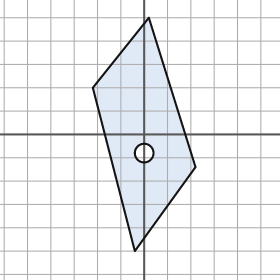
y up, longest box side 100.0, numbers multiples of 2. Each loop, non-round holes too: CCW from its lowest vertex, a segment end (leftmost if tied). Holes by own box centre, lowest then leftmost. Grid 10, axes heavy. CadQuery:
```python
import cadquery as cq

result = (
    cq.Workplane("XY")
    .moveTo(-4.0, -50.0)
    .lineTo(22.0, -14.0)
    .lineTo(2.0, 50.0)
    .lineTo(-22.0, 20.0)
    .close()
    .moveTo(0.0, -8.0)
    .circle(4.0)
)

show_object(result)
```